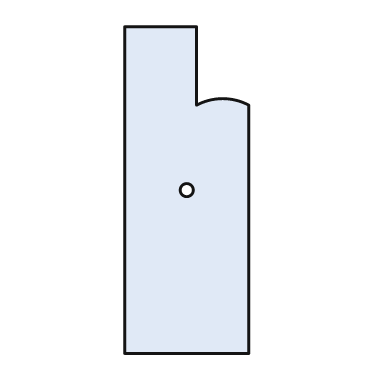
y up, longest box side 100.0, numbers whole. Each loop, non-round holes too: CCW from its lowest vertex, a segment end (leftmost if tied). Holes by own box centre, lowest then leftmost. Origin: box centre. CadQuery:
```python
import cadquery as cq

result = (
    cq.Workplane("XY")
    .moveTo(-19.0, -50.0)
    .lineTo(19.0, -50.0)
    .lineTo(19.0, 26.0)
    .threePointArc((11.0, 28.0), (3.0, 26.0))
    .lineTo(3.0, 50.0)
    .lineTo(-19.0, 50.0)
    .close()
    .moveTo(0.0, 0.0)
    .circle(2.0)
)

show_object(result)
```